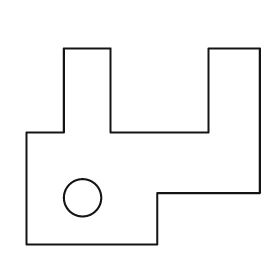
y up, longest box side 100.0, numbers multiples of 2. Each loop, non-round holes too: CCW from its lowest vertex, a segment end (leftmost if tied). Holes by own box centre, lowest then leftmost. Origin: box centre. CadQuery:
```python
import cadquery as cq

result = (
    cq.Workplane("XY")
    .moveTo(-50.0, -42.0)
    .lineTo(6.0, -42.0)
    .lineTo(6.0, -20.0)
    .lineTo(50.0, -20.0)
    .lineTo(50.0, 42.0)
    .lineTo(28.0, 42.0)
    .lineTo(28.0, 6.0)
    .lineTo(-14.0, 6.0)
    .lineTo(-14.0, 42.0)
    .lineTo(-34.0, 42.0)
    .lineTo(-34.0, 6.0)
    .lineTo(-50.0, 6.0)
    .close()
    .moveTo(-26.0, -22.0)
    .circle(8.0)
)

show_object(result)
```